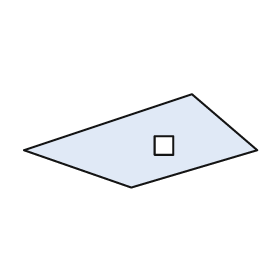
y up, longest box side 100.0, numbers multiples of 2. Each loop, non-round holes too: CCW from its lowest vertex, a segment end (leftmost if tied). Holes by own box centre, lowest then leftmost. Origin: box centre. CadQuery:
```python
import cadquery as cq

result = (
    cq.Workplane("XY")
    .moveTo(-4.0, -20.0)
    .lineTo(50.0, -4.0)
    .lineTo(22.0, 20.0)
    .lineTo(-50.0, -4.0)
    .close()
    .moveTo(6.0, -6.0)
    .lineTo(14.0, -6.0)
    .lineTo(14.0, 2.0)
    .lineTo(6.0, 2.0)
    .close()
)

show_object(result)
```